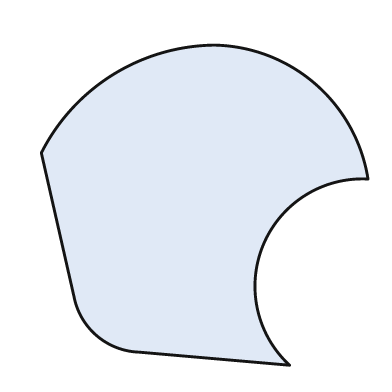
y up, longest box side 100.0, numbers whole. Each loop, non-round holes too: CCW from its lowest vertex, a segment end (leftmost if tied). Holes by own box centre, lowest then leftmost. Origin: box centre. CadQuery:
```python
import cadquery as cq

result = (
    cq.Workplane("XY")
    .moveTo(26.0, -49.0)
    .threePointArc((18.0, -12.0), (50.0, 8.0))
    .threePointArc((34.0, 37.0), (3.0, 49.0))
    .threePointArc((-28.0, 40.0), (-50.0, 16.0))
    .lineTo(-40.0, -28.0)
    .threePointArc((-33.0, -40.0), (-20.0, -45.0))
    .close()
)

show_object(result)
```